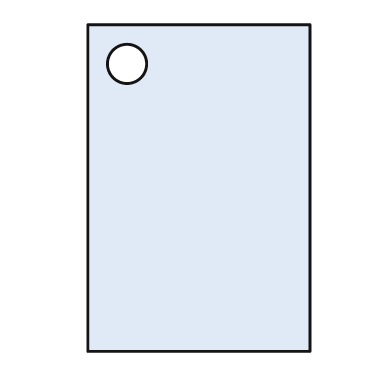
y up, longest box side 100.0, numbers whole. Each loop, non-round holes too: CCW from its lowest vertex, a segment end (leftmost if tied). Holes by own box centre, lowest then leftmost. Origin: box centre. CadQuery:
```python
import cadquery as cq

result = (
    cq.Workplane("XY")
    .moveTo(-34.0, -50.0)
    .lineTo(34.0, -50.0)
    .lineTo(34.0, 50.0)
    .lineTo(-34.0, 50.0)
    .close()
    .moveTo(-22.0, 38.0)
    .circle(6.0)
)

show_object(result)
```